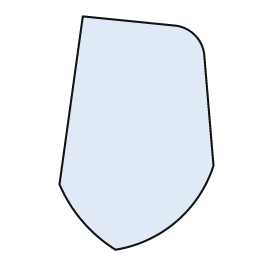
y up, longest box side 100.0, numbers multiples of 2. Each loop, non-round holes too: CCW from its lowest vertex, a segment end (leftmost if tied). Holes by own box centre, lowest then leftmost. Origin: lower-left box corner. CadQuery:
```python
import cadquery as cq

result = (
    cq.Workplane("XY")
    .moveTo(24.0, 0.0)
    .threePointArc((50.0, 12.0), (66.0, 36.0))
    .lineTo(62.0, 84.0)
    .threePointArc((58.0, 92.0), (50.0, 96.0))
    .lineTo(10.0, 100.0)
    .lineTo(0.0, 28.0)
    .threePointArc((10.0, 12.0), (24.0, 0.0))
    .close()
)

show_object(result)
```